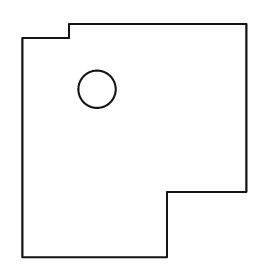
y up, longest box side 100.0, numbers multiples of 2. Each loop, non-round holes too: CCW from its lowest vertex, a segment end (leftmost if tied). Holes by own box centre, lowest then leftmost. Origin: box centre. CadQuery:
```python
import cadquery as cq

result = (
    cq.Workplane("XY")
    .moveTo(-48.0, -50.0)
    .lineTo(14.0, -50.0)
    .lineTo(14.0, -22.0)
    .lineTo(48.0, -22.0)
    .lineTo(48.0, 50.0)
    .lineTo(-28.0, 50.0)
    .lineTo(-28.0, 44.0)
    .lineTo(-48.0, 44.0)
    .close()
    .moveTo(-16.0, 22.0)
    .circle(8.0)
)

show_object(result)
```